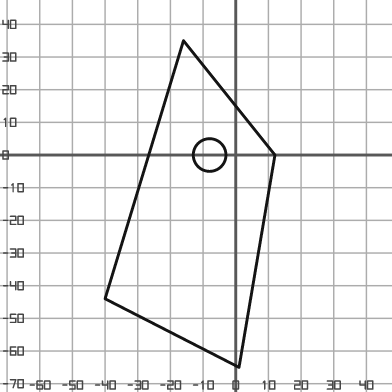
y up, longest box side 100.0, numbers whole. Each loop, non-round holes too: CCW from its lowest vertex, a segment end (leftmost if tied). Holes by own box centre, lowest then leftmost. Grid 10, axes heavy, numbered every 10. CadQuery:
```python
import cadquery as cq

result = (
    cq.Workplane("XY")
    .moveTo(1.0, -65.0)
    .lineTo(12.0, 0.0)
    .lineTo(-16.0, 35.0)
    .lineTo(-40.0, -44.0)
    .close()
    .moveTo(-8.0, 0.0)
    .circle(5.0)
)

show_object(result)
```